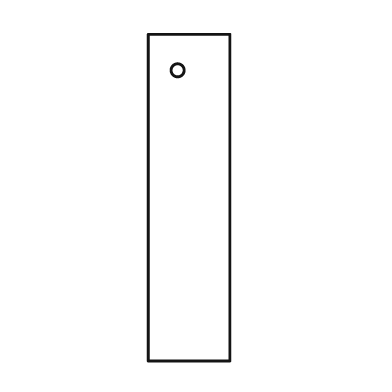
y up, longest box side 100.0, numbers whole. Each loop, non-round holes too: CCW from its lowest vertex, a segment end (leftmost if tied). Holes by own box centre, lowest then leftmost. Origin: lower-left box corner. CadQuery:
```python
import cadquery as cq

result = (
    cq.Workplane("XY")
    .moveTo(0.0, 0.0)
    .lineTo(25.0, 0.0)
    .lineTo(25.0, 100.0)
    .lineTo(0.0, 100.0)
    .close()
    .moveTo(9.0, 89.0)
    .circle(2.0)
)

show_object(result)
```